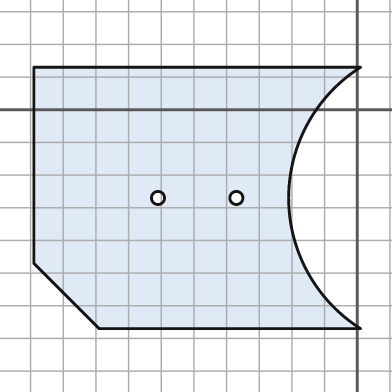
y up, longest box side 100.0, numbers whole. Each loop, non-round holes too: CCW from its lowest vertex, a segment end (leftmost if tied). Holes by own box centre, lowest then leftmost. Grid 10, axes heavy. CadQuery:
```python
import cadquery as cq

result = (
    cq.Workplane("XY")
    .moveTo(-79.0, -67.0)
    .lineTo(1.0, -67.0)
    .threePointArc((-21.0, -27.0), (1.0, 13.0))
    .lineTo(-99.0, 13.0)
    .lineTo(-99.0, -47.0)
    .close()
    .moveTo(-61.0, -27.0)
    .circle(2.0)
    .moveTo(-37.0, -27.0)
    .circle(2.0)
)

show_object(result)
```